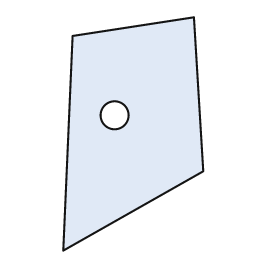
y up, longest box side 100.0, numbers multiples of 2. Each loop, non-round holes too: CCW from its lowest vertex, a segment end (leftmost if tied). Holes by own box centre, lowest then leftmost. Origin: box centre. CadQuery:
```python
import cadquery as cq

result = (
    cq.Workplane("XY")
    .moveTo(-30.0, -50.0)
    .lineTo(30.0, -16.0)
    .lineTo(26.0, 50.0)
    .lineTo(-26.0, 42.0)
    .close()
    .moveTo(-8.0, 8.0)
    .circle(6.0)
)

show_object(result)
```